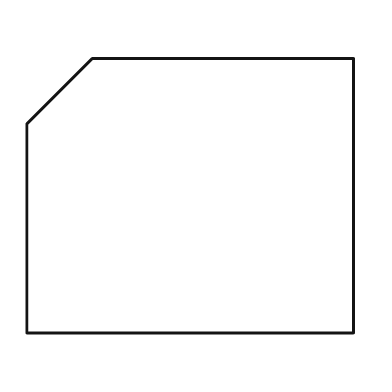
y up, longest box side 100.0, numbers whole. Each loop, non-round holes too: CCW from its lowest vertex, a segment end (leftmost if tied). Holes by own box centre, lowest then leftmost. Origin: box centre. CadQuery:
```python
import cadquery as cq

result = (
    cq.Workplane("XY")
    .moveTo(-50.0, -42.0)
    .lineTo(50.0, -42.0)
    .lineTo(50.0, 42.0)
    .lineTo(-30.0, 42.0)
    .lineTo(-50.0, 22.0)
    .close()
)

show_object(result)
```